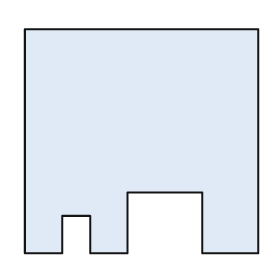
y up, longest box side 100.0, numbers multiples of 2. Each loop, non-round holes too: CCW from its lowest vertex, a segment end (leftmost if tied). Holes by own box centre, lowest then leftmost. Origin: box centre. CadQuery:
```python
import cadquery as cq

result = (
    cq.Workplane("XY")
    .moveTo(-50.0, -48.0)
    .lineTo(-34.0, -48.0)
    .lineTo(-34.0, -32.0)
    .lineTo(-22.0, -32.0)
    .lineTo(-22.0, -48.0)
    .lineTo(-6.0, -48.0)
    .lineTo(-6.0, -22.0)
    .lineTo(26.0, -22.0)
    .lineTo(26.0, -48.0)
    .lineTo(50.0, -48.0)
    .lineTo(50.0, 48.0)
    .lineTo(-50.0, 48.0)
    .close()
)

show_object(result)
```